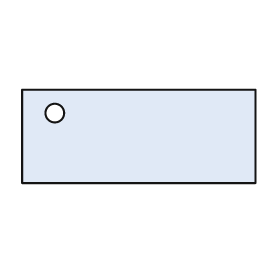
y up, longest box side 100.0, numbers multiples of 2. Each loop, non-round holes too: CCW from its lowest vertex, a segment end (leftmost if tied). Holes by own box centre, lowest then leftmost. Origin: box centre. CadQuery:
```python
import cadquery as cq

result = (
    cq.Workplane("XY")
    .moveTo(-50.0, -20.0)
    .lineTo(50.0, -20.0)
    .lineTo(50.0, 20.0)
    .lineTo(-50.0, 20.0)
    .close()
    .moveTo(-36.0, 10.0)
    .circle(4.0)
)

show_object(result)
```